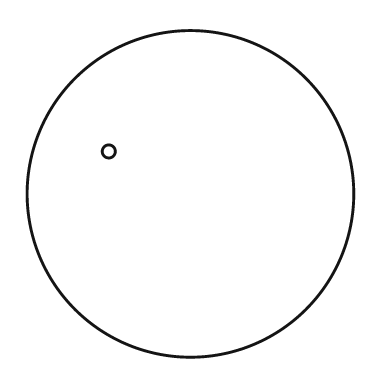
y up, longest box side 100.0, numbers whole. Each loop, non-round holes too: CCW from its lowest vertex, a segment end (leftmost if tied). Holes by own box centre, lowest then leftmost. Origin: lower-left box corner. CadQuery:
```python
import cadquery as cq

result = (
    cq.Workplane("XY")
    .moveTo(50.0, 50.0)
    .circle(50.0)
    .moveTo(25.0, 63.0)
    .circle(2.0)
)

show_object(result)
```